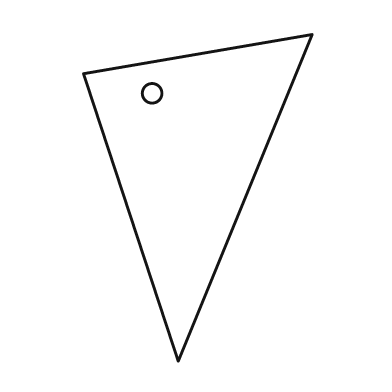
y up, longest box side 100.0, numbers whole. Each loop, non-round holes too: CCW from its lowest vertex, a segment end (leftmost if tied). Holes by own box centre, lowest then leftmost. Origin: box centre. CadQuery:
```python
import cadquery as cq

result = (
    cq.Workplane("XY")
    .moveTo(-6.0, -50.0)
    .lineTo(35.0, 50.0)
    .lineTo(-35.0, 38.0)
    .close()
    .moveTo(-14.0, 32.0)
    .circle(3.0)
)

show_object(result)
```